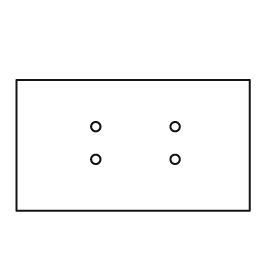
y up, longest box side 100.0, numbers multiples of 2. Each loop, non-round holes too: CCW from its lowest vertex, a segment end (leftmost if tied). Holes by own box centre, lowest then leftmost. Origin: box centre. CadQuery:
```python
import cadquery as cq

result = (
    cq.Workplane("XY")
    .moveTo(-50.0, -28.0)
    .lineTo(50.0, -28.0)
    .lineTo(50.0, 28.0)
    .lineTo(-50.0, 28.0)
    .close()
    .moveTo(-16.0, -6.0)
    .circle(2.0)
    .moveTo(18.0, -6.0)
    .circle(2.0)
    .moveTo(-16.0, 8.0)
    .circle(2.0)
    .moveTo(18.0, 8.0)
    .circle(2.0)
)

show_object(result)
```